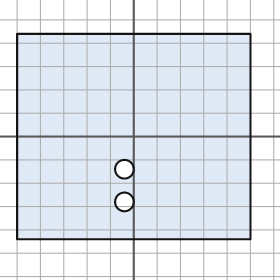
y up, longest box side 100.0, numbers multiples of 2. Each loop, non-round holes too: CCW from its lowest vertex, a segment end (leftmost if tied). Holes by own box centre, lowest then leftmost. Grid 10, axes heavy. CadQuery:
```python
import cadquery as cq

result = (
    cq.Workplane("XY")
    .moveTo(-50.0, -44.0)
    .lineTo(50.0, -44.0)
    .lineTo(50.0, 44.0)
    .lineTo(-50.0, 44.0)
    .close()
    .moveTo(-4.0, -28.0)
    .circle(4.0)
    .moveTo(-4.0, -14.0)
    .circle(4.0)
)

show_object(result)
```